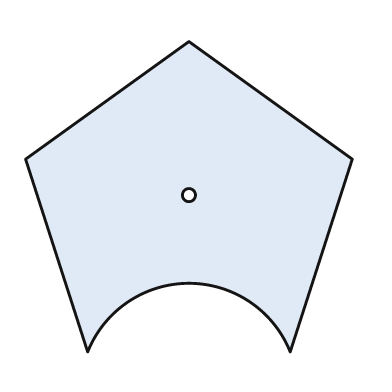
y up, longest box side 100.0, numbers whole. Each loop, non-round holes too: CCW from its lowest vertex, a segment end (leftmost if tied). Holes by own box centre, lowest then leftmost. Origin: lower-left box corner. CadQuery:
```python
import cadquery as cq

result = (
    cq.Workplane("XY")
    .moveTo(19.0, 0.0)
    .threePointArc((50.0, 21.0), (81.0, 0.0))
    .lineTo(100.0, 59.0)
    .lineTo(50.0, 95.0)
    .lineTo(0.0, 59.0)
    .close()
    .moveTo(50.0, 48.0)
    .circle(2.0)
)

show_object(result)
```